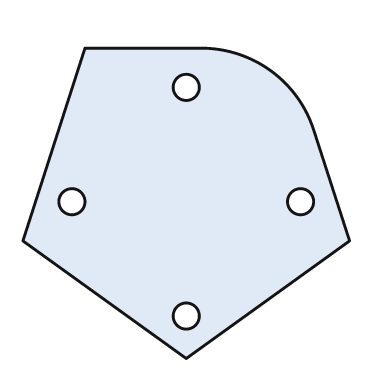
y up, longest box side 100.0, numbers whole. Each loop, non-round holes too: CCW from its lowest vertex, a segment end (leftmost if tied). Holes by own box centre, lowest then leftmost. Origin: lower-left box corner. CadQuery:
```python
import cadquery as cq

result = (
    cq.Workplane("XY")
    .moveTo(50.0, 0.0)
    .lineTo(100.0, 36.0)
    .lineTo(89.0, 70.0)
    .threePointArc((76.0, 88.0), (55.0, 95.0))
    .lineTo(19.0, 95.0)
    .lineTo(0.0, 36.0)
    .close()
    .moveTo(50.0, 13.0)
    .circle(4.0)
    .moveTo(15.0, 48.0)
    .circle(4.0)
    .moveTo(85.0, 48.0)
    .circle(4.0)
    .moveTo(50.0, 83.0)
    .circle(4.0)
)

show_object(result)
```